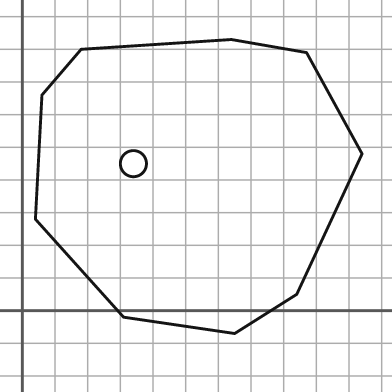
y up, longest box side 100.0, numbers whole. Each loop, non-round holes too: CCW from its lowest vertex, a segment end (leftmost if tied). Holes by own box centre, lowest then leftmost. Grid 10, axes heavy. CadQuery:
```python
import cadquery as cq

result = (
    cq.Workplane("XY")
    .moveTo(65.0, -7.0)
    .lineTo(84.0, 5.0)
    .lineTo(104.0, 48.0)
    .lineTo(87.0, 79.0)
    .lineTo(64.0, 83.0)
    .lineTo(18.0, 80.0)
    .lineTo(6.0, 66.0)
    .lineTo(4.0, 28.0)
    .lineTo(31.0, -2.0)
    .close()
    .moveTo(34.0, 45.0)
    .circle(4.0)
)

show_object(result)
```